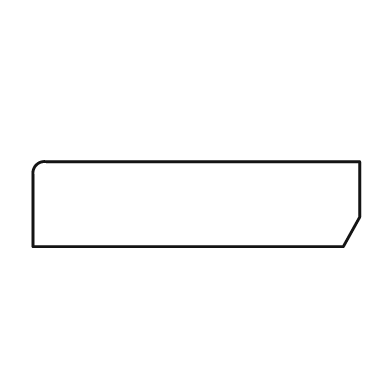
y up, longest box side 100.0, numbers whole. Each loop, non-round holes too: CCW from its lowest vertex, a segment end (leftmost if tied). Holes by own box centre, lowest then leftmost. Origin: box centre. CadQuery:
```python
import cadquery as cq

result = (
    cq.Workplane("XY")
    .moveTo(-50.0, -13.0)
    .lineTo(45.0, -13.0)
    .lineTo(50.0, -4.0)
    .lineTo(50.0, 13.0)
    .lineTo(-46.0, 13.0)
    .threePointArc((-49.0, 12.0), (-50.0, 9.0))
    .close()
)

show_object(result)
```